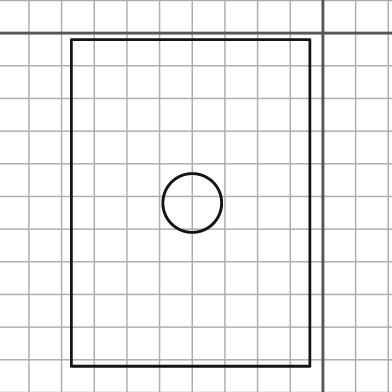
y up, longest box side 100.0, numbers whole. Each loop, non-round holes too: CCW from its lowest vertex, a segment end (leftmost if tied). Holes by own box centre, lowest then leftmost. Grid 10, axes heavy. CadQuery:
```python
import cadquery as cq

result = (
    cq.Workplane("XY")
    .moveTo(-77.0, -102.0)
    .lineTo(-4.0, -102.0)
    .lineTo(-4.0, -2.0)
    .lineTo(-77.0, -2.0)
    .close()
    .moveTo(-40.0, -52.0)
    .circle(9.0)
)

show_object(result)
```